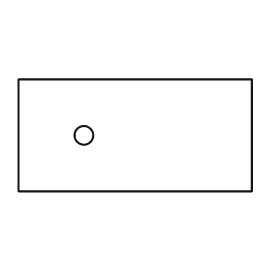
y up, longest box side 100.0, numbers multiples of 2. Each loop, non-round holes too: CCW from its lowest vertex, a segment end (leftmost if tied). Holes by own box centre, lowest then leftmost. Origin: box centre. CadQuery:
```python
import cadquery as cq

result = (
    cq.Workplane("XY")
    .moveTo(-50.0, -24.0)
    .lineTo(50.0, -24.0)
    .lineTo(50.0, 24.0)
    .lineTo(-50.0, 24.0)
    .close()
    .moveTo(-22.0, 0.0)
    .circle(4.0)
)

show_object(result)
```